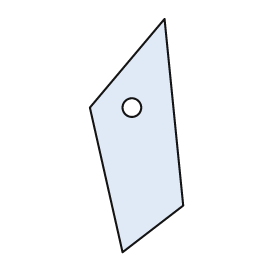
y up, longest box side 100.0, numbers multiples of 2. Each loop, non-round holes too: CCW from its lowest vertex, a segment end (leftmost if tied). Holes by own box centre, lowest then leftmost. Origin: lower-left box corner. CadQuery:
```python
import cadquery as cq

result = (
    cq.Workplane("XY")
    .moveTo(14.0, 0.0)
    .lineTo(40.0, 20.0)
    .lineTo(32.0, 100.0)
    .lineTo(0.0, 62.0)
    .close()
    .moveTo(18.0, 62.0)
    .circle(4.0)
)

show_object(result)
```